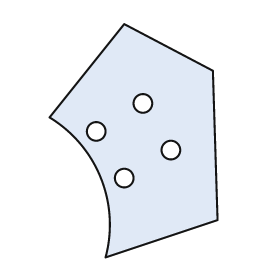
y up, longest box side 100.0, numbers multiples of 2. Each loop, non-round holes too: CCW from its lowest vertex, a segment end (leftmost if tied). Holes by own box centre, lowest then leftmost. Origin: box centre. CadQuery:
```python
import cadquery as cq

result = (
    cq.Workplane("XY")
    .moveTo(-12.0, -50.0)
    .lineTo(36.0, -34.0)
    .lineTo(34.0, 30.0)
    .lineTo(-4.0, 50.0)
    .lineTo(-36.0, 10.0)
    .threePointArc((-14.0, -16.0), (-12.0, -50.0))
    .close()
    .moveTo(-4.0, -16.0)
    .circle(4.0)
    .moveTo(16.0, -4.0)
    .circle(4.0)
    .moveTo(-16.0, 4.0)
    .circle(4.0)
    .moveTo(4.0, 16.0)
    .circle(4.0)
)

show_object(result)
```